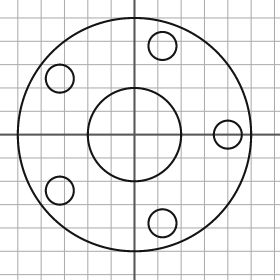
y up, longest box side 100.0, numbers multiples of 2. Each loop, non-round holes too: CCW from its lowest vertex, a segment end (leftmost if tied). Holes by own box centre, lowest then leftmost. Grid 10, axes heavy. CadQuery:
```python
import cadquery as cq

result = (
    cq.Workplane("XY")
    .moveTo(0.0, 0.0)
    .circle(50.0)
    .moveTo(12.0, -38.0)
    .circle(6.0)
    .moveTo(-32.0, -24.0)
    .circle(6.0)
    .moveTo(0.0, 0.0)
    .circle(20.0)
    .moveTo(40.0, 0.0)
    .circle(6.0)
    .moveTo(-32.0, 24.0)
    .circle(6.0)
    .moveTo(12.0, 38.0)
    .circle(6.0)
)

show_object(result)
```